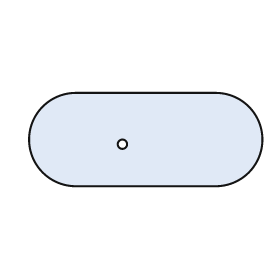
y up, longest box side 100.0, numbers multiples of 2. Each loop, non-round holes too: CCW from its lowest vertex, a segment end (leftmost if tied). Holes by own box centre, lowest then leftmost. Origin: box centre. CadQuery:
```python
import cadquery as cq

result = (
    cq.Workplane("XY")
    .moveTo(-30.0, -20.0)
    .lineTo(30.0, -20.0)
    .threePointArc((50.0, 0.0), (30.0, 20.0))
    .lineTo(-30.0, 20.0)
    .threePointArc((-50.0, 0.0), (-30.0, -20.0))
    .close()
    .moveTo(-10.0, -2.0)
    .circle(2.0)
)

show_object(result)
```